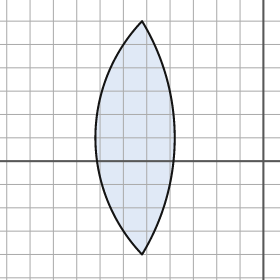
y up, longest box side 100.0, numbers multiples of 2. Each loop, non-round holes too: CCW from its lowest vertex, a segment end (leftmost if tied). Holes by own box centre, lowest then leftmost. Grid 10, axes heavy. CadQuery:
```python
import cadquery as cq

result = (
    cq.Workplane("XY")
    .moveTo(-52.0, -40.0)
    .threePointArc((-38.0, 10.0), (-52.0, 60.0))
    .threePointArc((-72.0, 10.0), (-52.0, -40.0))
    .close()
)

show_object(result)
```